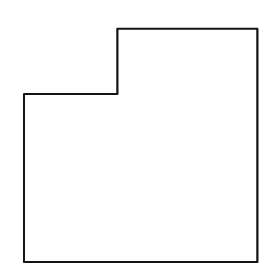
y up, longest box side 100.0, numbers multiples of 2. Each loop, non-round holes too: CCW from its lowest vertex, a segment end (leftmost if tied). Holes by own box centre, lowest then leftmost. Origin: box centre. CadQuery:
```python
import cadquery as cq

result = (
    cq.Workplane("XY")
    .moveTo(-50.0, -50.0)
    .lineTo(50.0, -50.0)
    .lineTo(50.0, 50.0)
    .lineTo(-10.0, 50.0)
    .lineTo(-10.0, 22.0)
    .lineTo(-50.0, 22.0)
    .close()
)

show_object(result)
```